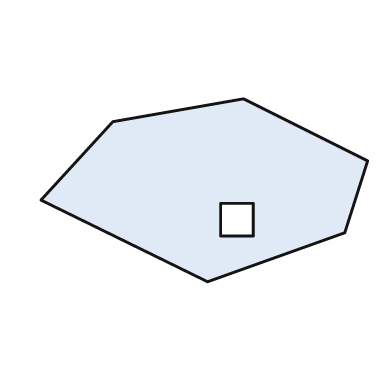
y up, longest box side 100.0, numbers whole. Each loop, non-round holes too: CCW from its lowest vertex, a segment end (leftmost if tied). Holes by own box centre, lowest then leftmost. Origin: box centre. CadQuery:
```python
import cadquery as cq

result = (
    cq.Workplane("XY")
    .moveTo(1.0, -28.0)
    .lineTo(43.0, -13.0)
    .lineTo(50.0, 9.0)
    .lineTo(12.0, 28.0)
    .lineTo(-28.0, 21.0)
    .lineTo(-50.0, -3.0)
    .close()
    .moveTo(5.0, -14.0)
    .lineTo(15.0, -14.0)
    .lineTo(15.0, -4.0)
    .lineTo(5.0, -4.0)
    .close()
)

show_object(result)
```